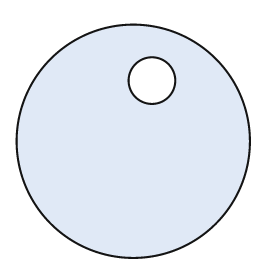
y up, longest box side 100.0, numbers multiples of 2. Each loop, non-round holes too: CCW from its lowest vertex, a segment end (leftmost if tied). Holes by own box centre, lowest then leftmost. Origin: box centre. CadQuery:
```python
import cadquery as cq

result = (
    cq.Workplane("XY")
    .moveTo(0.0, 0.0)
    .circle(50.0)
    .moveTo(8.0, 26.0)
    .circle(10.0)
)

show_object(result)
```